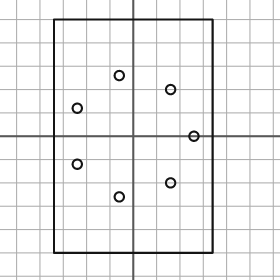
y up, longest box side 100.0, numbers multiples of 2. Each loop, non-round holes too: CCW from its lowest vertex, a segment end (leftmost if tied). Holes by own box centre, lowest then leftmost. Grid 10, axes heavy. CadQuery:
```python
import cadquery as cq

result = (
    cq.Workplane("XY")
    .moveTo(-34.0, -50.0)
    .lineTo(34.0, -50.0)
    .lineTo(34.0, 50.0)
    .lineTo(-34.0, 50.0)
    .close()
    .moveTo(-6.0, -26.0)
    .circle(2.0)
    .moveTo(16.0, -20.0)
    .circle(2.0)
    .moveTo(-24.0, -12.0)
    .circle(2.0)
    .moveTo(26.0, 0.0)
    .circle(2.0)
    .moveTo(-24.0, 12.0)
    .circle(2.0)
    .moveTo(16.0, 20.0)
    .circle(2.0)
    .moveTo(-6.0, 26.0)
    .circle(2.0)
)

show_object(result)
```